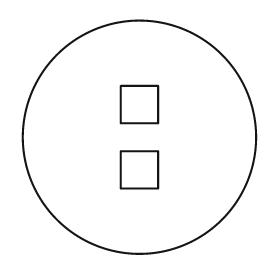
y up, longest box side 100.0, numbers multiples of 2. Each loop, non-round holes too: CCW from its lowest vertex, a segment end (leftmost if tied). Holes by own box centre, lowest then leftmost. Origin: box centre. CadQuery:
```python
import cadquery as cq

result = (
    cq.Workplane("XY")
    .moveTo(0.0, 0.0)
    .circle(50.0)
    .moveTo(-8.0, -22.0)
    .lineTo(8.0, -22.0)
    .lineTo(8.0, -6.0)
    .lineTo(-8.0, -6.0)
    .close()
    .moveTo(-8.0, 6.0)
    .lineTo(8.0, 6.0)
    .lineTo(8.0, 22.0)
    .lineTo(-8.0, 22.0)
    .close()
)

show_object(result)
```